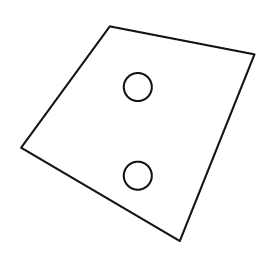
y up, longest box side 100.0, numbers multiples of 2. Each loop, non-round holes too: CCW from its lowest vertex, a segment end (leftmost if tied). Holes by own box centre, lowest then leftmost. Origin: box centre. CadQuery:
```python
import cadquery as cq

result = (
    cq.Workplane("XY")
    .moveTo(18.0, -46.0)
    .lineTo(50.0, 34.0)
    .lineTo(-12.0, 46.0)
    .lineTo(-50.0, -6.0)
    .close()
    .moveTo(0.0, -18.0)
    .circle(6.0)
    .moveTo(0.0, 20.0)
    .circle(6.0)
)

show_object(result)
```